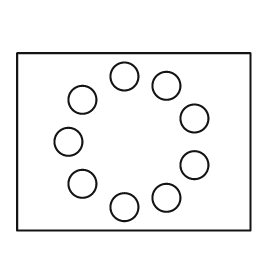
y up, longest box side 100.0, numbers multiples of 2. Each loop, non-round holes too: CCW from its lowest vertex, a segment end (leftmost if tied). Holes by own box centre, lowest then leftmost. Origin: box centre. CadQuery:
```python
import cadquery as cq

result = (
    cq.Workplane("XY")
    .moveTo(-50.0, -38.0)
    .lineTo(50.0, -38.0)
    .lineTo(50.0, 38.0)
    .lineTo(-50.0, 38.0)
    .close()
    .moveTo(-4.0, -28.0)
    .circle(6.0)
    .moveTo(14.0, -24.0)
    .circle(6.0)
    .moveTo(-22.0, -18.0)
    .circle(6.0)
    .moveTo(26.0, -10.0)
    .circle(6.0)
    .moveTo(-28.0, 0.0)
    .circle(6.0)
    .moveTo(26.0, 10.0)
    .circle(6.0)
    .moveTo(-22.0, 18.0)
    .circle(6.0)
    .moveTo(14.0, 24.0)
    .circle(6.0)
    .moveTo(-4.0, 28.0)
    .circle(6.0)
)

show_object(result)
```